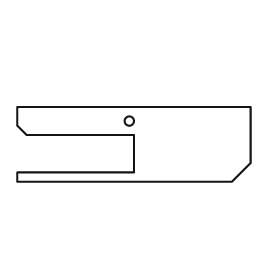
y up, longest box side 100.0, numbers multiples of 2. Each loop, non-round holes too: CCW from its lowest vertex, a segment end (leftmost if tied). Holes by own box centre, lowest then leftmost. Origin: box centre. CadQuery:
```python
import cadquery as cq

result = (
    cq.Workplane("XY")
    .moveTo(-50.0, -16.0)
    .lineTo(42.0, -16.0)
    .lineTo(50.0, -8.0)
    .lineTo(50.0, 16.0)
    .lineTo(-50.0, 16.0)
    .lineTo(-50.0, 8.0)
    .lineTo(-46.0, 4.0)
    .lineTo(0.0, 4.0)
    .lineTo(0.0, -12.0)
    .lineTo(-50.0, -12.0)
    .close()
    .moveTo(-2.0, 10.0)
    .circle(2.0)
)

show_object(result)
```